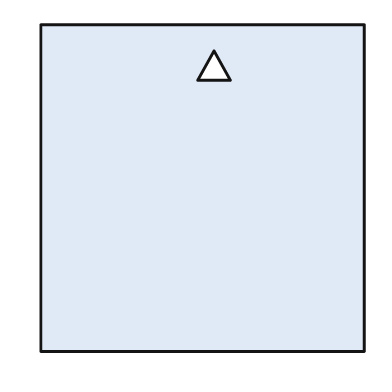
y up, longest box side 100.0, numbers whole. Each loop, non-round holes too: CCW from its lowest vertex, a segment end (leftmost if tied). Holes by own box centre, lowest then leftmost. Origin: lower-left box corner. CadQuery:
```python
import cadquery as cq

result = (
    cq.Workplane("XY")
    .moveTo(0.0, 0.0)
    .lineTo(99.0, 0.0)
    .lineTo(99.0, 100.0)
    .lineTo(0.0, 100.0)
    .close()
    .moveTo(48.0, 83.0)
    .lineTo(58.0, 83.0)
    .lineTo(53.0, 92.0)
    .close()
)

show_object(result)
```